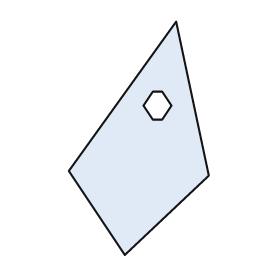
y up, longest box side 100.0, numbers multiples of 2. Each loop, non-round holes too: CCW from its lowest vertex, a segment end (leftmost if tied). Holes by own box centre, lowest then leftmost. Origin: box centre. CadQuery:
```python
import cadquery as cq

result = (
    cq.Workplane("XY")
    .moveTo(-6.0, -50.0)
    .lineTo(30.0, -16.0)
    .lineTo(16.0, 50.0)
    .lineTo(-30.0, -14.0)
    .close()
    .moveTo(6.0, 8.0)
    .lineTo(10.0, 8.0)
    .lineTo(14.0, 14.0)
    .lineTo(10.0, 20.0)
    .lineTo(6.0, 20.0)
    .lineTo(2.0, 14.0)
    .close()
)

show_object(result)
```